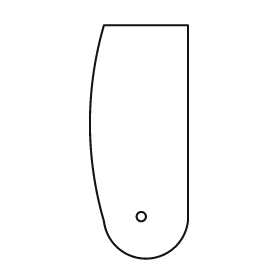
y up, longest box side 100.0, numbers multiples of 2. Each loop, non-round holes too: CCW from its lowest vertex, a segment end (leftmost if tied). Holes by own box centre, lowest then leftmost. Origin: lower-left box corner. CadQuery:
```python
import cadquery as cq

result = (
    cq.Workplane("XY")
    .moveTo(6.0, 16.0)
    .threePointArc((24.0, 0.0), (42.0, 16.0))
    .lineTo(42.0, 100.0)
    .lineTo(6.0, 100.0)
    .threePointArc((0.0, 58.0), (6.0, 16.0))
    .close()
    .moveTo(22.0, 18.0)
    .circle(2.0)
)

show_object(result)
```